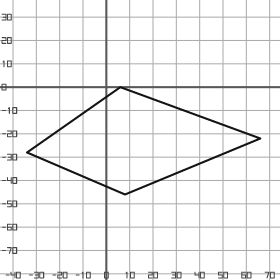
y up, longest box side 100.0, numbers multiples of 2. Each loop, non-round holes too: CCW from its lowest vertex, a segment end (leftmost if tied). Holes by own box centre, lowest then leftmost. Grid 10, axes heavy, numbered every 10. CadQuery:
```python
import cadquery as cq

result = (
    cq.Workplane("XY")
    .moveTo(8.0, -46.0)
    .lineTo(66.0, -22.0)
    .lineTo(6.0, 0.0)
    .lineTo(-34.0, -28.0)
    .close()
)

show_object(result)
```